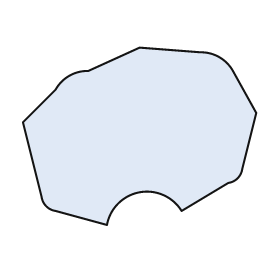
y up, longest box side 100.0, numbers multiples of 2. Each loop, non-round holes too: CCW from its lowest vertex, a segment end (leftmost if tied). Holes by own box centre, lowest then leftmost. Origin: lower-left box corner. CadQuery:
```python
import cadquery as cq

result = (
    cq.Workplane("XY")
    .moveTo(36.0, 0.0)
    .threePointArc((50.0, 14.0), (68.0, 6.0))
    .lineTo(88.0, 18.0)
    .threePointArc((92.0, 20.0), (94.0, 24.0))
    .lineTo(100.0, 48.0)
    .lineTo(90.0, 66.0)
    .threePointArc((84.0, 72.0), (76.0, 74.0))
    .lineTo(50.0, 76.0)
    .lineTo(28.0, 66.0)
    .threePointArc((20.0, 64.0), (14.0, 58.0))
    .lineTo(0.0, 44.0)
    .lineTo(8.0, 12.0)
    .threePointArc((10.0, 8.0), (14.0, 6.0))
    .close()
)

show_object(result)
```